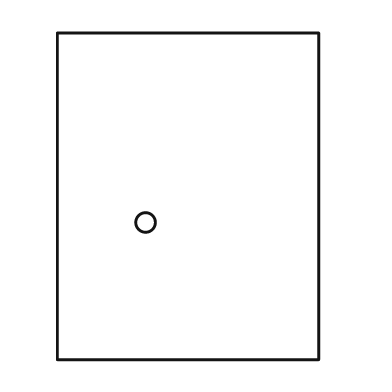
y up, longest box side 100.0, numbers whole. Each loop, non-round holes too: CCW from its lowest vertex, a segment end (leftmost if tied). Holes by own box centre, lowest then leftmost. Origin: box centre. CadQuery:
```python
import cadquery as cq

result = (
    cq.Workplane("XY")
    .moveTo(-40.0, -50.0)
    .lineTo(40.0, -50.0)
    .lineTo(40.0, 50.0)
    .lineTo(-40.0, 50.0)
    .close()
    .moveTo(-13.0, -8.0)
    .circle(3.0)
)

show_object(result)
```